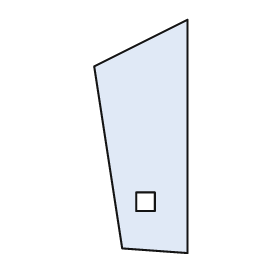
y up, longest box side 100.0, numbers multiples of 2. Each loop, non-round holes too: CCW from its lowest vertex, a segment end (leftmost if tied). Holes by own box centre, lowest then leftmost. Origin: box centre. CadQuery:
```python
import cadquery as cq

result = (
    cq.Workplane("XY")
    .moveTo(20.0, -50.0)
    .lineTo(20.0, 50.0)
    .lineTo(-20.0, 30.0)
    .lineTo(-8.0, -48.0)
    .close()
    .moveTo(-2.0, -32.0)
    .lineTo(6.0, -32.0)
    .lineTo(6.0, -24.0)
    .lineTo(-2.0, -24.0)
    .close()
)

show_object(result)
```